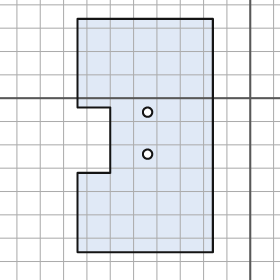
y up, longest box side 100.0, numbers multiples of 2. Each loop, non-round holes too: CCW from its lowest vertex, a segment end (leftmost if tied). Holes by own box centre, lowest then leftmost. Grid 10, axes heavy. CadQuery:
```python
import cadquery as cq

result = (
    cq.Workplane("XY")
    .moveTo(-74.0, -66.0)
    .lineTo(-16.0, -66.0)
    .lineTo(-16.0, 34.0)
    .lineTo(-74.0, 34.0)
    .lineTo(-74.0, -4.0)
    .lineTo(-60.0, -4.0)
    .lineTo(-60.0, -32.0)
    .lineTo(-74.0, -32.0)
    .close()
    .moveTo(-44.0, -24.0)
    .circle(2.0)
    .moveTo(-44.0, -6.0)
    .circle(2.0)
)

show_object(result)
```